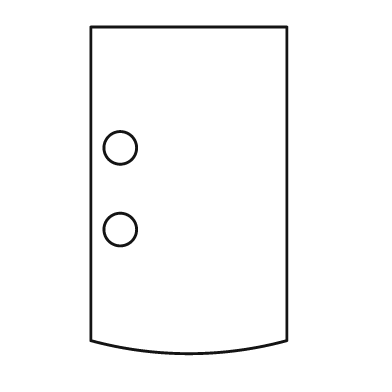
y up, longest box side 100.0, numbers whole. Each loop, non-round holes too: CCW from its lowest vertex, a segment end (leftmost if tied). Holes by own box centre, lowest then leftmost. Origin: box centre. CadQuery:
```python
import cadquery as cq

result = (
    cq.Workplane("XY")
    .moveTo(-30.0, -46.0)
    .threePointArc((0.0, -50.0), (30.0, -46.0))
    .lineTo(30.0, 50.0)
    .lineTo(-30.0, 50.0)
    .close()
    .moveTo(-21.0, -12.0)
    .circle(5.0)
    .moveTo(-21.0, 13.0)
    .circle(5.0)
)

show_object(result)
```